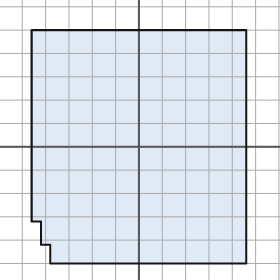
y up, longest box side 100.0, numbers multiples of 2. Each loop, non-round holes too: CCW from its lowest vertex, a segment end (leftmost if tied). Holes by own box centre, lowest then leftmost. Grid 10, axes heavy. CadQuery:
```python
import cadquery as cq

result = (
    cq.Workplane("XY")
    .moveTo(-38.0, -50.0)
    .lineTo(46.0, -50.0)
    .lineTo(46.0, 50.0)
    .lineTo(-46.0, 50.0)
    .lineTo(-46.0, -32.0)
    .lineTo(-42.0, -32.0)
    .lineTo(-42.0, -42.0)
    .lineTo(-38.0, -42.0)
    .close()
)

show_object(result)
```